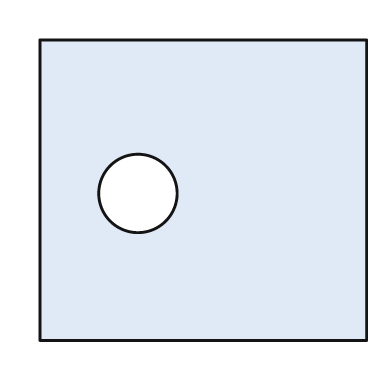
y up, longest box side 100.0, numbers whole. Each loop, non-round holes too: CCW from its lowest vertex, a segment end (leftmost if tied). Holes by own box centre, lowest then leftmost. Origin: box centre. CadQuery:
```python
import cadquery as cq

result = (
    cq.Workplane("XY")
    .moveTo(-50.0, -46.0)
    .lineTo(50.0, -46.0)
    .lineTo(50.0, 46.0)
    .lineTo(-50.0, 46.0)
    .close()
    .moveTo(-20.0, -1.0)
    .circle(12.0)
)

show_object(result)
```